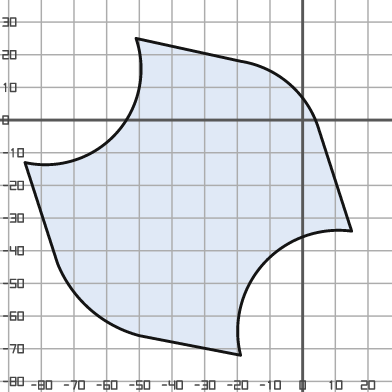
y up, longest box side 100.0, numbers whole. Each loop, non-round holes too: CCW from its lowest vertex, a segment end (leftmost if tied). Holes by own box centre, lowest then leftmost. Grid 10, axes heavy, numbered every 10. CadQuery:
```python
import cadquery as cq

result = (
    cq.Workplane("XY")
    .moveTo(-19.0, -72.0)
    .threePointArc((-12.0, -44.0), (15.0, -34.0))
    .lineTo(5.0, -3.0)
    .threePointArc((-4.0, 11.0), (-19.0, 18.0))
    .lineTo(-51.0, 25.0)
    .threePointArc((-57.0, -4.0), (-85.0, -13.0))
    .lineTo(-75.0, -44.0)
    .threePointArc((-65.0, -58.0), (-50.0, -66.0))
    .close()
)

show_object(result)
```